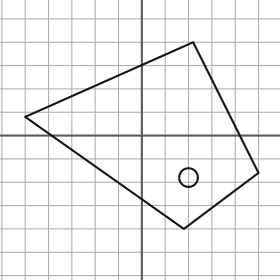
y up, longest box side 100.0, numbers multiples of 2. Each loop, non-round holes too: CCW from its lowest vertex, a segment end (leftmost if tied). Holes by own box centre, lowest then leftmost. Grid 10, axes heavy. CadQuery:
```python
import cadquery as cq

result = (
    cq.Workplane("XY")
    .moveTo(18.0, -40.0)
    .lineTo(50.0, -16.0)
    .lineTo(22.0, 40.0)
    .lineTo(-50.0, 8.0)
    .close()
    .moveTo(20.0, -18.0)
    .circle(4.0)
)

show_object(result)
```